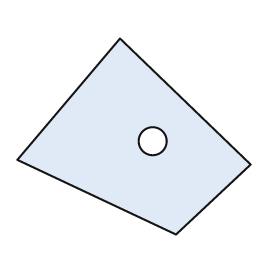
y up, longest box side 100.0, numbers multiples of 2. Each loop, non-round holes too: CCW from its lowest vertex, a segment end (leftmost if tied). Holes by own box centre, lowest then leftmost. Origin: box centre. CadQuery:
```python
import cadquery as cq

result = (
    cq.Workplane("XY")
    .moveTo(18.0, -42.0)
    .lineTo(50.0, -12.0)
    .lineTo(-6.0, 42.0)
    .lineTo(-50.0, -10.0)
    .close()
    .moveTo(8.0, -2.0)
    .circle(6.0)
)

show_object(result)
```